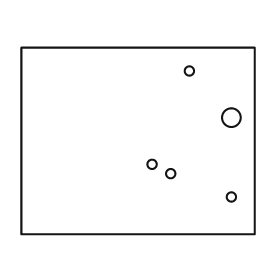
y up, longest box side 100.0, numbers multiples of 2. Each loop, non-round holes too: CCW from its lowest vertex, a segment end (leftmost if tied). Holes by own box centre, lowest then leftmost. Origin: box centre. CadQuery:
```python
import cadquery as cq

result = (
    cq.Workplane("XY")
    .moveTo(-50.0, -40.0)
    .lineTo(50.0, -40.0)
    .lineTo(50.0, 40.0)
    .lineTo(-50.0, 40.0)
    .close()
    .moveTo(40.0, -24.0)
    .circle(2.0)
    .moveTo(14.0, -14.0)
    .circle(2.0)
    .moveTo(6.0, -10.0)
    .circle(2.0)
    .moveTo(40.0, 10.0)
    .circle(4.0)
    .moveTo(22.0, 30.0)
    .circle(2.0)
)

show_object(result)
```